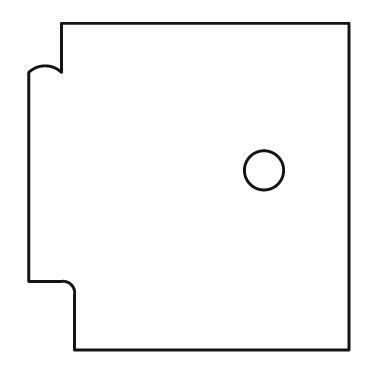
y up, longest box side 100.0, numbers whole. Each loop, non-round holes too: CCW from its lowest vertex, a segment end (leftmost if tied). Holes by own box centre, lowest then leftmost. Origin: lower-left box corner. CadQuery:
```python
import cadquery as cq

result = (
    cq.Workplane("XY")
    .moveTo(14.0, 0.0)
    .lineTo(98.0, 0.0)
    .lineTo(98.0, 100.0)
    .lineTo(10.0, 100.0)
    .lineTo(10.0, 85.0)
    .threePointArc((5.0, 87.0), (0.0, 85.0))
    .lineTo(0.0, 21.0)
    .lineTo(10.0, 21.0)
    .threePointArc((13.0, 20.0), (14.0, 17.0))
    .close()
    .moveTo(72.0, 55.0)
    .circle(6.0)
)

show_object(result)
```